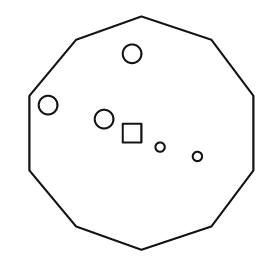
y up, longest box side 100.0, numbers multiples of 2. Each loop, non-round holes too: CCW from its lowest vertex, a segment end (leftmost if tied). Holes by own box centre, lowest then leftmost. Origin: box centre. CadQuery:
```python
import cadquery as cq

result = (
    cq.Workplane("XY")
    .moveTo(0.0, -50.0)
    .lineTo(30.0, -40.0)
    .lineTo(48.0, -16.0)
    .lineTo(48.0, 16.0)
    .lineTo(30.0, 40.0)
    .lineTo(0.0, 50.0)
    .lineTo(-28.0, 40.0)
    .lineTo(-48.0, 16.0)
    .lineTo(-48.0, -16.0)
    .lineTo(-28.0, -40.0)
    .close()
    .moveTo(24.0, -10.0)
    .circle(2.0)
    .moveTo(8.0, -6.0)
    .circle(2.0)
    .moveTo(-8.0, -4.0)
    .lineTo(0.0, -4.0)
    .lineTo(0.0, 4.0)
    .lineTo(-8.0, 4.0)
    .close()
    .moveTo(-16.0, 6.0)
    .circle(4.0)
    .moveTo(-40.0, 12.0)
    .circle(4.0)
    .moveTo(-4.0, 34.0)
    .circle(4.0)
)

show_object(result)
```